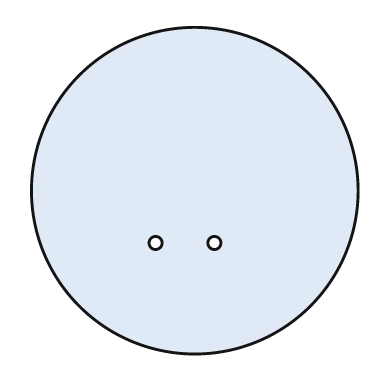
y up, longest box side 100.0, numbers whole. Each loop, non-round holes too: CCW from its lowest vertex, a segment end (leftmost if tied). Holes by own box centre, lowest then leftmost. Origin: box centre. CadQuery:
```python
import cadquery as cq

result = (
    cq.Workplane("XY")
    .moveTo(0.0, 0.0)
    .circle(50.0)
    .moveTo(-12.0, -16.0)
    .circle(2.0)
    .moveTo(6.0, -16.0)
    .circle(2.0)
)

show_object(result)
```